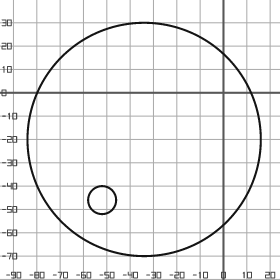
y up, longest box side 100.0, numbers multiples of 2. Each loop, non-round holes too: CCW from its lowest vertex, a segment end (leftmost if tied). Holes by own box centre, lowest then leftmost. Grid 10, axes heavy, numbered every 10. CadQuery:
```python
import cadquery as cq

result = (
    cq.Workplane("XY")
    .moveTo(-34.0, -20.0)
    .circle(50.0)
    .moveTo(-52.0, -46.0)
    .circle(6.0)
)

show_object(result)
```